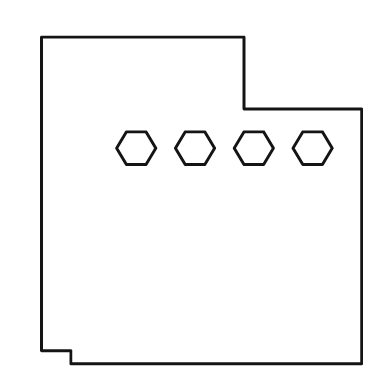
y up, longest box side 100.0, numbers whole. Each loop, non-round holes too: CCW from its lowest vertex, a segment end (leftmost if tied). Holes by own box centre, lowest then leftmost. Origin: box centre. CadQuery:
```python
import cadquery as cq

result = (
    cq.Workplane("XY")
    .moveTo(-40.0, -50.0)
    .lineTo(49.0, -50.0)
    .lineTo(49.0, 28.0)
    .lineTo(13.0, 28.0)
    .lineTo(13.0, 50.0)
    .lineTo(-49.0, 50.0)
    .lineTo(-49.0, -46.0)
    .lineTo(-40.0, -46.0)
    .close()
    .moveTo(-23.0, 11.0)
    .lineTo(-17.0, 11.0)
    .lineTo(-14.0, 16.0)
    .lineTo(-17.0, 21.0)
    .lineTo(-23.0, 21.0)
    .lineTo(-26.0, 16.0)
    .close()
    .moveTo(-5.0, 11.0)
    .lineTo(1.0, 11.0)
    .lineTo(4.0, 16.0)
    .lineTo(1.0, 21.0)
    .lineTo(-5.0, 21.0)
    .lineTo(-8.0, 16.0)
    .close()
    .moveTo(13.0, 11.0)
    .lineTo(19.0, 11.0)
    .lineTo(22.0, 16.0)
    .lineTo(19.0, 21.0)
    .lineTo(13.0, 21.0)
    .lineTo(10.0, 16.0)
    .close()
    .moveTo(31.0, 11.0)
    .lineTo(37.0, 11.0)
    .lineTo(40.0, 16.0)
    .lineTo(37.0, 21.0)
    .lineTo(31.0, 21.0)
    .lineTo(28.0, 16.0)
    .close()
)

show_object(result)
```